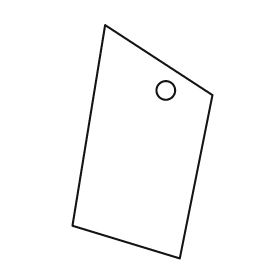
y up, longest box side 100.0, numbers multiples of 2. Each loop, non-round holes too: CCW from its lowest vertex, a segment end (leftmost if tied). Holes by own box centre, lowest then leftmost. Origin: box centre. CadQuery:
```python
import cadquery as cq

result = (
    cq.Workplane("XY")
    .moveTo(16.0, -50.0)
    .lineTo(30.0, 20.0)
    .lineTo(-16.0, 50.0)
    .lineTo(-30.0, -36.0)
    .close()
    .moveTo(10.0, 22.0)
    .circle(4.0)
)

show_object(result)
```